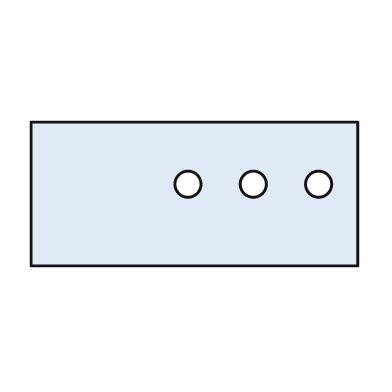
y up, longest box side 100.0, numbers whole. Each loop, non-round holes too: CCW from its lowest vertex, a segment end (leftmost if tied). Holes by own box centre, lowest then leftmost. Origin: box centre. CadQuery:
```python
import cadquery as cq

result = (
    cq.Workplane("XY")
    .moveTo(-50.0, -22.0)
    .lineTo(50.0, -22.0)
    .lineTo(50.0, 22.0)
    .lineTo(-50.0, 22.0)
    .close()
    .moveTo(-2.0, 3.0)
    .circle(4.0)
    .moveTo(18.0, 3.0)
    .circle(4.0)
    .moveTo(38.0, 3.0)
    .circle(4.0)
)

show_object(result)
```